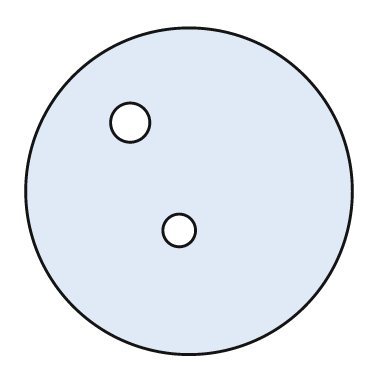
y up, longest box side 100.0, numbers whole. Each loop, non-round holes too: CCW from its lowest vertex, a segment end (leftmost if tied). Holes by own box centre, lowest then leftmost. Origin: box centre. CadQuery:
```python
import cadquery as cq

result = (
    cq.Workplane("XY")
    .moveTo(0.0, 0.0)
    .circle(50.0)
    .moveTo(-3.0, -12.0)
    .circle(5.0)
    .moveTo(-18.0, 21.0)
    .circle(6.0)
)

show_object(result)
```